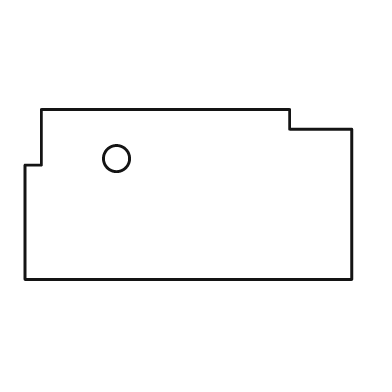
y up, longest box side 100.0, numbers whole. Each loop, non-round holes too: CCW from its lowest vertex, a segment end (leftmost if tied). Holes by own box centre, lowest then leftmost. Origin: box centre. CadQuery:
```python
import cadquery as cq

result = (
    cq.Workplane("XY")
    .moveTo(-50.0, -26.0)
    .lineTo(50.0, -26.0)
    .lineTo(50.0, 20.0)
    .lineTo(31.0, 20.0)
    .lineTo(31.0, 26.0)
    .lineTo(-45.0, 26.0)
    .lineTo(-45.0, 9.0)
    .lineTo(-50.0, 9.0)
    .close()
    .moveTo(-22.0, 11.0)
    .circle(4.0)
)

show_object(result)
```